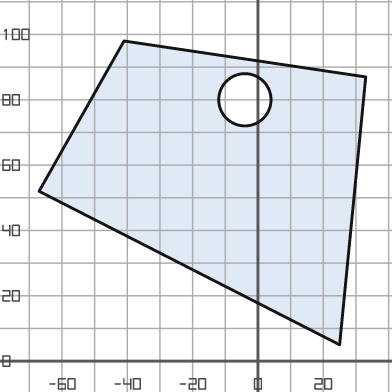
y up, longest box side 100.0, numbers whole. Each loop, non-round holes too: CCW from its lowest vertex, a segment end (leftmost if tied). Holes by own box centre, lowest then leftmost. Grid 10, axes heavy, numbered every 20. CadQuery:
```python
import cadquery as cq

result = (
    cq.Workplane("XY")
    .moveTo(25.0, 5.0)
    .lineTo(33.0, 87.0)
    .lineTo(-41.0, 98.0)
    .lineTo(-67.0, 52.0)
    .close()
    .moveTo(-4.0, 80.0)
    .circle(8.0)
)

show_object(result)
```